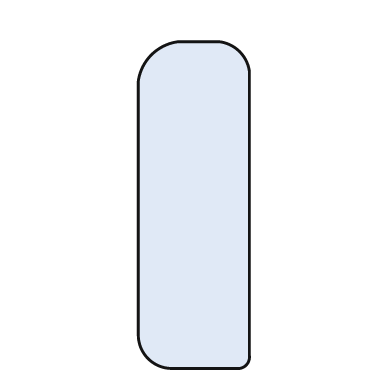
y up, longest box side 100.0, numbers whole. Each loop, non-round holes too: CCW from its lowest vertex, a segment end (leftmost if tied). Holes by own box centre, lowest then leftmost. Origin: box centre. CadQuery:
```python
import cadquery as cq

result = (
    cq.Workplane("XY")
    .moveTo(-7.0, -50.0)
    .lineTo(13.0, -50.0)
    .threePointArc((16.0, -49.0), (17.0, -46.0))
    .lineTo(17.0, 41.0)
    .threePointArc((14.0, 47.0), (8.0, 50.0))
    .lineTo(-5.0, 50.0)
    .threePointArc((-13.0, 46.0), (-17.0, 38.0))
    .lineTo(-17.0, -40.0)
    .threePointArc((-14.0, -47.0), (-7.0, -50.0))
    .close()
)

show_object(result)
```